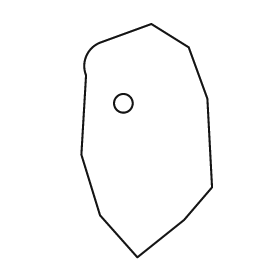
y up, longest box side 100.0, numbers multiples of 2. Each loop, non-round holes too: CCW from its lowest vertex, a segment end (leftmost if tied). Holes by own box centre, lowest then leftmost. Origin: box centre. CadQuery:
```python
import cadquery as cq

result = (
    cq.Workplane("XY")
    .moveTo(-4.0, -50.0)
    .lineTo(16.0, -34.0)
    .lineTo(28.0, -20.0)
    .lineTo(26.0, 18.0)
    .lineTo(18.0, 40.0)
    .lineTo(2.0, 50.0)
    .lineTo(-20.0, 42.0)
    .threePointArc((-26.0, 36.0), (-26.0, 28.0))
    .lineTo(-28.0, -6.0)
    .lineTo(-20.0, -32.0)
    .close()
    .moveTo(-10.0, 16.0)
    .circle(4.0)
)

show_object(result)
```